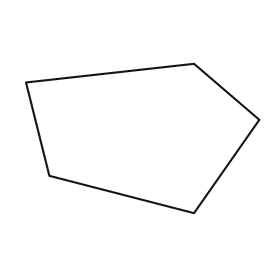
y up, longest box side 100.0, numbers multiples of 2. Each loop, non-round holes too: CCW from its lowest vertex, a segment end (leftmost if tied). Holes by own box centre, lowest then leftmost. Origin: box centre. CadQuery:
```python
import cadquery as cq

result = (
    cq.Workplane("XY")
    .moveTo(22.0, -32.0)
    .lineTo(50.0, 8.0)
    .lineTo(22.0, 32.0)
    .lineTo(-50.0, 24.0)
    .lineTo(-40.0, -16.0)
    .close()
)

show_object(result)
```